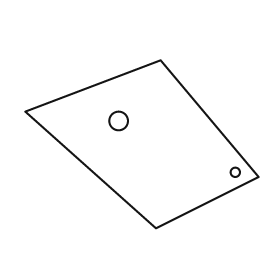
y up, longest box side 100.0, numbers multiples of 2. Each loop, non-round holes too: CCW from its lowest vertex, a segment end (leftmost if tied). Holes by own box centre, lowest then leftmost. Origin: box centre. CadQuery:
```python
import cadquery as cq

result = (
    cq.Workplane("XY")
    .moveTo(6.0, -36.0)
    .lineTo(50.0, -14.0)
    .lineTo(8.0, 36.0)
    .lineTo(-50.0, 14.0)
    .close()
    .moveTo(40.0, -12.0)
    .circle(2.0)
    .moveTo(-10.0, 10.0)
    .circle(4.0)
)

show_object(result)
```